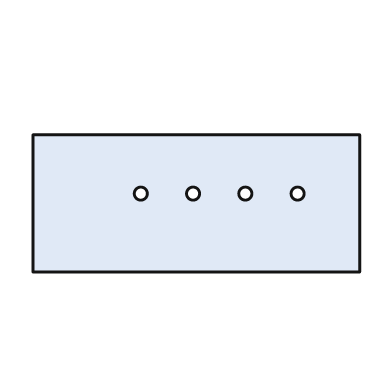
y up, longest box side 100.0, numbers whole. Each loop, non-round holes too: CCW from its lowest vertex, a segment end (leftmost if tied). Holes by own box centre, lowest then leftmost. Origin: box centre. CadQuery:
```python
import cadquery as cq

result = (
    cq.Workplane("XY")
    .moveTo(-50.0, -21.0)
    .lineTo(50.0, -21.0)
    .lineTo(50.0, 21.0)
    .lineTo(-50.0, 21.0)
    .close()
    .moveTo(-17.0, 3.0)
    .circle(2.0)
    .moveTo(-1.0, 3.0)
    .circle(2.0)
    .moveTo(15.0, 3.0)
    .circle(2.0)
    .moveTo(31.0, 3.0)
    .circle(2.0)
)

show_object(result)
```